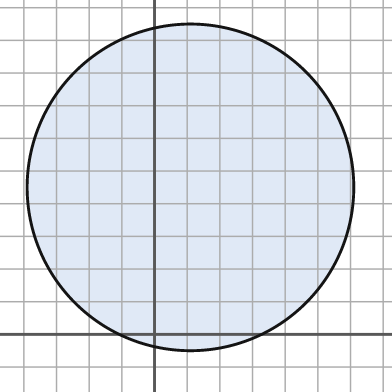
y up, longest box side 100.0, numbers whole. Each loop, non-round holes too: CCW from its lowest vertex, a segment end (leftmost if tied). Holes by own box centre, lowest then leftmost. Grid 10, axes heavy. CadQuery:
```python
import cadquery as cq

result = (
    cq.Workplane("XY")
    .moveTo(11.0, 45.0)
    .circle(50.0)
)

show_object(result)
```